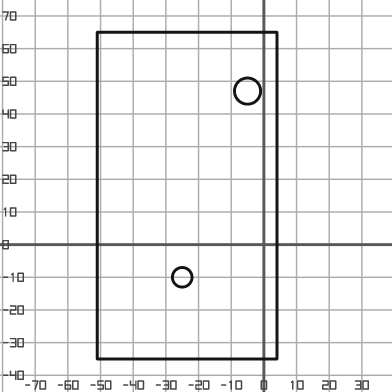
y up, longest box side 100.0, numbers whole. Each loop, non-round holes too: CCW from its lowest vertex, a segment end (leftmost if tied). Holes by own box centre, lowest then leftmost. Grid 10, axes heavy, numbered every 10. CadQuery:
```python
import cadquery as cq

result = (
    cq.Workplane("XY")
    .moveTo(-51.0, -35.0)
    .lineTo(4.0, -35.0)
    .lineTo(4.0, 65.0)
    .lineTo(-51.0, 65.0)
    .close()
    .moveTo(-25.0, -10.0)
    .circle(3.0)
    .moveTo(-5.0, 47.0)
    .circle(4.0)
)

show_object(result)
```